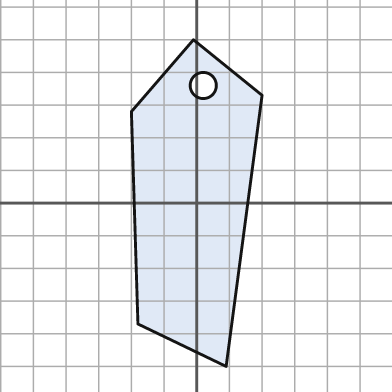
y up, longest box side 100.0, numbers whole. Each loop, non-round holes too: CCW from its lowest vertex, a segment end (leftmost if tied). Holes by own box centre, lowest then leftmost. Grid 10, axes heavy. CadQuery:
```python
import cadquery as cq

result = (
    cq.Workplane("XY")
    .moveTo(9.0, -50.0)
    .lineTo(20.0, 33.0)
    .lineTo(-1.0, 50.0)
    .lineTo(-20.0, 28.0)
    .lineTo(-18.0, -37.0)
    .close()
    .moveTo(2.0, 36.0)
    .circle(4.0)
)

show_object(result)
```